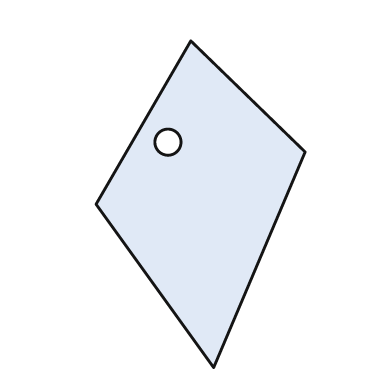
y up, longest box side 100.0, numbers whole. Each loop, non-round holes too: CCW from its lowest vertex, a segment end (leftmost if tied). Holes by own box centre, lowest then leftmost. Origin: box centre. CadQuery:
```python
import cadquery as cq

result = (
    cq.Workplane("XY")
    .moveTo(4.0, -50.0)
    .lineTo(32.0, 16.0)
    .lineTo(-3.0, 50.0)
    .lineTo(-32.0, 0.0)
    .close()
    .moveTo(-10.0, 19.0)
    .circle(4.0)
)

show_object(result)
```